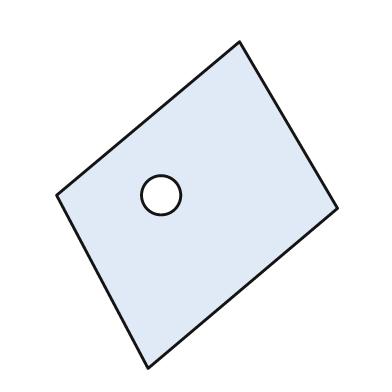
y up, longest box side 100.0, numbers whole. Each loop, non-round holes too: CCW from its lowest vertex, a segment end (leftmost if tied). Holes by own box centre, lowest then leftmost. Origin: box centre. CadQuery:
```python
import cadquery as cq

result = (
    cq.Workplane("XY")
    .moveTo(-15.0, -50.0)
    .lineTo(43.0, -1.0)
    .lineTo(13.0, 50.0)
    .lineTo(-43.0, 3.0)
    .close()
    .moveTo(-11.0, 3.0)
    .circle(6.0)
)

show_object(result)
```